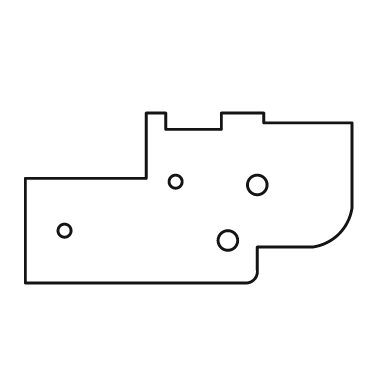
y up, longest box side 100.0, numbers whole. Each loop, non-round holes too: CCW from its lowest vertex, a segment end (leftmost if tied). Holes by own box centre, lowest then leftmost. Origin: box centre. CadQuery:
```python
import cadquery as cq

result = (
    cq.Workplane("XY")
    .moveTo(-50.0, -26.0)
    .lineTo(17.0, -26.0)
    .threePointArc((20.0, -25.0), (21.0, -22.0))
    .lineTo(21.0, -15.0)
    .lineTo(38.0, -15.0)
    .threePointArc((46.0, -11.0), (50.0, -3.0))
    .lineTo(50.0, 23.0)
    .lineTo(23.0, 23.0)
    .lineTo(23.0, 26.0)
    .lineTo(10.0, 26.0)
    .lineTo(10.0, 21.0)
    .lineTo(-7.0, 21.0)
    .lineTo(-7.0, 26.0)
    .lineTo(-13.0, 26.0)
    .lineTo(-13.0, 6.0)
    .lineTo(-50.0, 6.0)
    .close()
    .moveTo(12.0, -13.0)
    .circle(3.0)
    .moveTo(-38.0, -10.0)
    .circle(2.0)
    .moveTo(21.0, 4.0)
    .circle(3.0)
    .moveTo(-4.0, 5.0)
    .circle(2.0)
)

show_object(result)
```